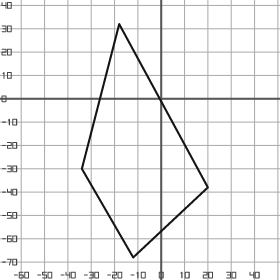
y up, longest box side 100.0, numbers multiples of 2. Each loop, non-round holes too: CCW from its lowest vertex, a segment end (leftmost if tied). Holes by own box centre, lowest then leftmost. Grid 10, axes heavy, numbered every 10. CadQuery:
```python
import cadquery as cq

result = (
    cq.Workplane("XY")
    .moveTo(-12.0, -68.0)
    .lineTo(20.0, -38.0)
    .lineTo(-18.0, 32.0)
    .lineTo(-34.0, -30.0)
    .close()
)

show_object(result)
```